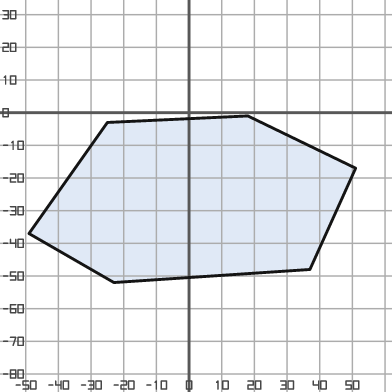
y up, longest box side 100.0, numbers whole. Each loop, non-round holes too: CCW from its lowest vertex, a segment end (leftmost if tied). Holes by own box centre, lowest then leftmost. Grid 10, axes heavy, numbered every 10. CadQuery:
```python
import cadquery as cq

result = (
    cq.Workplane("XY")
    .moveTo(-23.0, -52.0)
    .lineTo(37.0, -48.0)
    .lineTo(51.0, -17.0)
    .lineTo(18.0, -1.0)
    .lineTo(-25.0, -3.0)
    .lineTo(-49.0, -37.0)
    .close()
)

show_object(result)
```